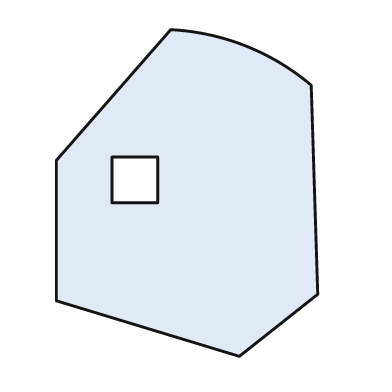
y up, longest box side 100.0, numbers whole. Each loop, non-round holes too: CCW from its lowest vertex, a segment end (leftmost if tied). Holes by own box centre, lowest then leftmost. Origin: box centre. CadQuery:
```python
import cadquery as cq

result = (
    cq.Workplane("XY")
    .moveTo(16.0, -50.0)
    .lineTo(40.0, -31.0)
    .lineTo(38.0, 33.0)
    .threePointArc((18.0, 45.0), (-5.0, 50.0))
    .lineTo(-40.0, 10.0)
    .lineTo(-40.0, -33.0)
    .close()
    .moveTo(-23.0, -3.0)
    .lineTo(-9.0, -3.0)
    .lineTo(-9.0, 11.0)
    .lineTo(-23.0, 11.0)
    .close()
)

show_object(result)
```